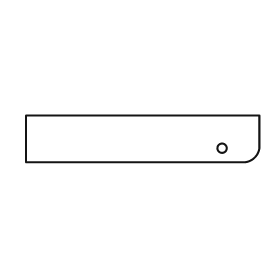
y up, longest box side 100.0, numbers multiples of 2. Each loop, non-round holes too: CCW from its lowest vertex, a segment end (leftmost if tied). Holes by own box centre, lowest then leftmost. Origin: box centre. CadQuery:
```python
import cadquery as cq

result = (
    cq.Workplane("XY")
    .moveTo(-50.0, -10.0)
    .lineTo(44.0, -10.0)
    .threePointArc((48.0, -8.0), (50.0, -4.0))
    .lineTo(50.0, 10.0)
    .lineTo(-50.0, 10.0)
    .close()
    .moveTo(34.0, -4.0)
    .circle(2.0)
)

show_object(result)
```